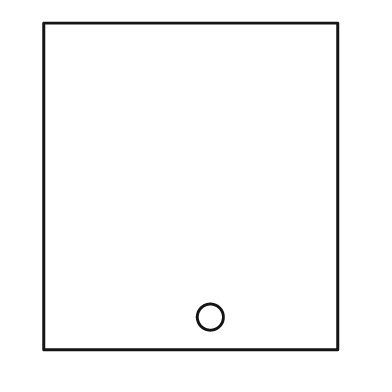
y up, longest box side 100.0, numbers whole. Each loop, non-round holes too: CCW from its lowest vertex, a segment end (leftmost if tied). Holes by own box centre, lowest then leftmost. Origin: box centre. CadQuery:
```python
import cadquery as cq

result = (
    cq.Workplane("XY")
    .moveTo(-45.0, -50.0)
    .lineTo(45.0, -50.0)
    .lineTo(45.0, 50.0)
    .lineTo(-45.0, 50.0)
    .close()
    .moveTo(6.0, -40.0)
    .circle(4.0)
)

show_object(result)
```